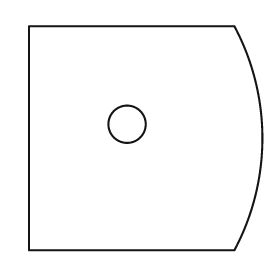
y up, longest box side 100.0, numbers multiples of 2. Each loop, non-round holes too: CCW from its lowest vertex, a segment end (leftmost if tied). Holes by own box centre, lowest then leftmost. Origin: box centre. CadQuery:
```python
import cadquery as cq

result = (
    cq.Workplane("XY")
    .moveTo(-50.0, -48.0)
    .lineTo(38.0, -48.0)
    .threePointArc((50.0, 0.0), (38.0, 48.0))
    .lineTo(-50.0, 48.0)
    .close()
    .moveTo(-8.0, 6.0)
    .circle(8.0)
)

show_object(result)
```